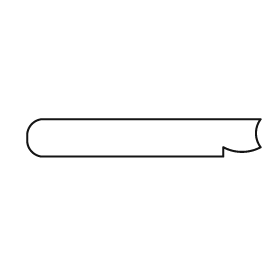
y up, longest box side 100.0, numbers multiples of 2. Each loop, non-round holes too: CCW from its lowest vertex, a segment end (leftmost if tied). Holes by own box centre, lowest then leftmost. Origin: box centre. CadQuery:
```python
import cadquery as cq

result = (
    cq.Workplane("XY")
    .moveTo(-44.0, -8.0)
    .lineTo(34.0, -8.0)
    .lineTo(34.0, -4.0)
    .threePointArc((42.0, -6.0), (50.0, -4.0))
    .threePointArc((48.0, 2.0), (50.0, 8.0))
    .lineTo(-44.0, 8.0)
    .threePointArc((-48.0, 6.0), (-50.0, 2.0))
    .lineTo(-50.0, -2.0)
    .threePointArc((-48.0, -6.0), (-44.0, -8.0))
    .close()
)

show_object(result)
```